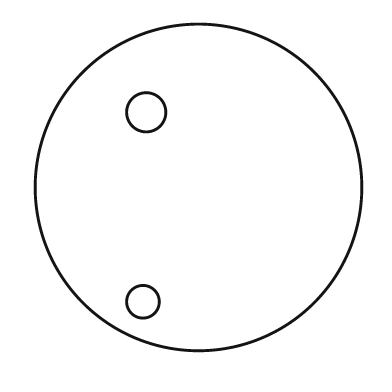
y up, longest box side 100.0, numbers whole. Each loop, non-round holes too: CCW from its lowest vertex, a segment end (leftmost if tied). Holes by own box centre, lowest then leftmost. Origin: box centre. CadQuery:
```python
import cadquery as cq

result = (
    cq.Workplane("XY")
    .moveTo(0.0, 0.0)
    .circle(50.0)
    .moveTo(-17.0, -35.0)
    .circle(5.0)
    .moveTo(-16.0, 23.0)
    .circle(6.0)
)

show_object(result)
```